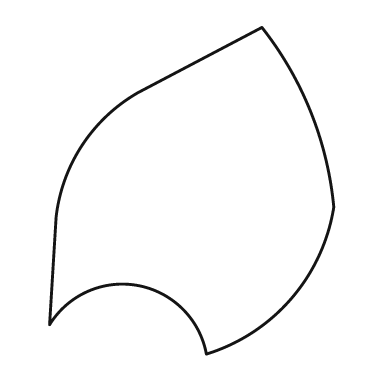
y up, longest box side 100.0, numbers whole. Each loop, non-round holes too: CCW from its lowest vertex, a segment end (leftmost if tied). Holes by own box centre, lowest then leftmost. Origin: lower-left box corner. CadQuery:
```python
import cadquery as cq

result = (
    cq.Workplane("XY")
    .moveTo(48.0, 0.0)
    .threePointArc((74.0, 17.0), (87.0, 45.0))
    .threePointArc((80.0, 74.0), (65.0, 100.0))
    .lineTo(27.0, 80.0)
    .threePointArc((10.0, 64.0), (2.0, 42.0))
    .lineTo(0.0, 9.0)
    .threePointArc((27.0, 21.0), (48.0, 0.0))
    .close()
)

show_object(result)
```